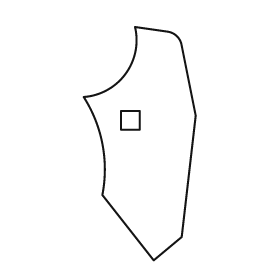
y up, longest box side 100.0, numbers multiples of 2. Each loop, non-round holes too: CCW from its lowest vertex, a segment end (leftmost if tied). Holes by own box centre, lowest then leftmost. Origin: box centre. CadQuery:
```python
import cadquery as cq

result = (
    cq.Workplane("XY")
    .moveTo(6.0, -50.0)
    .lineTo(18.0, -40.0)
    .lineTo(24.0, 12.0)
    .lineTo(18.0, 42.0)
    .threePointArc((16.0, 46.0), (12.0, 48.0))
    .lineTo(-2.0, 50.0)
    .threePointArc((-6.0, 30.0), (-24.0, 20.0))
    .threePointArc((-16.0, 0.0), (-16.0, -22.0))
    .close()
    .moveTo(-8.0, 6.0)
    .lineTo(0.0, 6.0)
    .lineTo(0.0, 14.0)
    .lineTo(-8.0, 14.0)
    .close()
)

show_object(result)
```